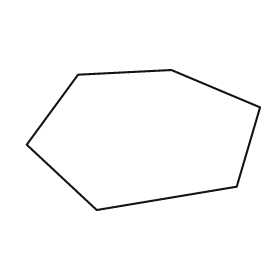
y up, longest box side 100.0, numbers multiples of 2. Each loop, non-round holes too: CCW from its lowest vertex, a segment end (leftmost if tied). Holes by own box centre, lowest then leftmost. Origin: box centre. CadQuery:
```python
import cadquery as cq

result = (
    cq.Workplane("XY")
    .moveTo(-20.0, -30.0)
    .lineTo(40.0, -20.0)
    .lineTo(50.0, 14.0)
    .lineTo(12.0, 30.0)
    .lineTo(-28.0, 28.0)
    .lineTo(-50.0, -2.0)
    .close()
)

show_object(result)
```